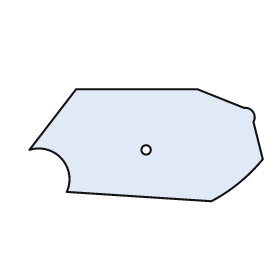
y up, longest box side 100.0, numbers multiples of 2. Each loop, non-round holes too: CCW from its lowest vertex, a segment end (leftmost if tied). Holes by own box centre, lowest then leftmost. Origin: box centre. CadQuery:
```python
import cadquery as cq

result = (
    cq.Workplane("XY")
    .moveTo(28.0, -24.0)
    .threePointArc((40.0, -16.0), (50.0, -6.0))
    .lineTo(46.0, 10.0)
    .threePointArc((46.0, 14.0), (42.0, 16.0))
    .lineTo(22.0, 24.0)
    .lineTo(-30.0, 24.0)
    .lineTo(-50.0, -2.0)
    .threePointArc((-36.0, -6.0), (-34.0, -20.0))
    .close()
    .moveTo(0.0, -2.0)
    .circle(2.0)
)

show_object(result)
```